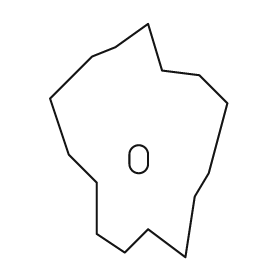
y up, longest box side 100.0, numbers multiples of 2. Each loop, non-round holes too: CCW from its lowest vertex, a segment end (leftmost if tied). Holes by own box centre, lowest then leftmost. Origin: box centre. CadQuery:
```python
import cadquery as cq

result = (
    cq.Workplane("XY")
    .moveTo(20.0, -50.0)
    .lineTo(24.0, -24.0)
    .lineTo(30.0, -14.0)
    .lineTo(38.0, 16.0)
    .lineTo(26.0, 28.0)
    .lineTo(10.0, 30.0)
    .lineTo(4.0, 50.0)
    .lineTo(-10.0, 40.0)
    .lineTo(-20.0, 36.0)
    .lineTo(-38.0, 18.0)
    .lineTo(-30.0, -6.0)
    .lineTo(-18.0, -18.0)
    .lineTo(-18.0, -40.0)
    .lineTo(-6.0, -48.0)
    .lineTo(4.0, -38.0)
    .close()
    .moveTo(-4.0, -10.0)
    .threePointArc((0.0, -14.0), (4.0, -10.0))
    .lineTo(4.0, -6.0)
    .threePointArc((0.0, -2.0), (-4.0, -6.0))
    .close()
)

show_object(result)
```